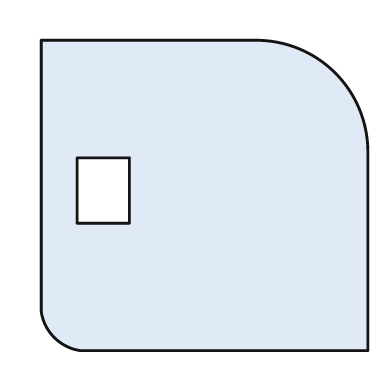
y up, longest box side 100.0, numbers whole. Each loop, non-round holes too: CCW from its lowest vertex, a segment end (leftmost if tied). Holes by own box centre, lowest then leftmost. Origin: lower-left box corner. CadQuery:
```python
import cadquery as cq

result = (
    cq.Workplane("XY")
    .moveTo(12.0, 0.0)
    .lineTo(100.0, 0.0)
    .lineTo(100.0, 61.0)
    .threePointArc((90.0, 85.0), (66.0, 95.0))
    .lineTo(0.0, 95.0)
    .lineTo(0.0, 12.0)
    .threePointArc((4.0, 4.0), (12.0, 0.0))
    .close()
    .moveTo(11.0, 39.0)
    .lineTo(27.0, 39.0)
    .lineTo(27.0, 59.0)
    .lineTo(11.0, 59.0)
    .close()
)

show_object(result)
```